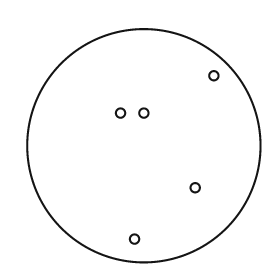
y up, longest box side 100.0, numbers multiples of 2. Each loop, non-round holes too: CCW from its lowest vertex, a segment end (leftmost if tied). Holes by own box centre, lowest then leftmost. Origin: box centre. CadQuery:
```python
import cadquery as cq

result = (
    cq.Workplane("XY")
    .moveTo(0.0, 0.0)
    .circle(50.0)
    .moveTo(-4.0, -40.0)
    .circle(2.0)
    .moveTo(22.0, -18.0)
    .circle(2.0)
    .moveTo(-10.0, 14.0)
    .circle(2.0)
    .moveTo(0.0, 14.0)
    .circle(2.0)
    .moveTo(30.0, 30.0)
    .circle(2.0)
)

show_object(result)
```